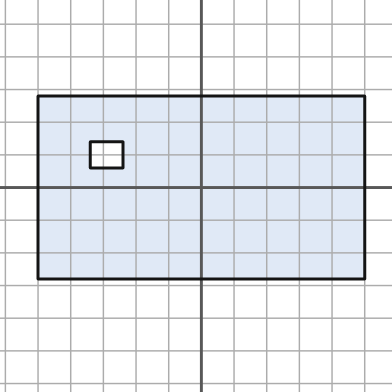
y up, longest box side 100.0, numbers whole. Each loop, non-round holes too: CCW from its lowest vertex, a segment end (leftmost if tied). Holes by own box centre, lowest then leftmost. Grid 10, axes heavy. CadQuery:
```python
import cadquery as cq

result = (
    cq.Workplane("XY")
    .moveTo(-50.0, -28.0)
    .lineTo(50.0, -28.0)
    .lineTo(50.0, 28.0)
    .lineTo(-50.0, 28.0)
    .close()
    .moveTo(-34.0, 6.0)
    .lineTo(-24.0, 6.0)
    .lineTo(-24.0, 14.0)
    .lineTo(-34.0, 14.0)
    .close()
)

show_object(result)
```